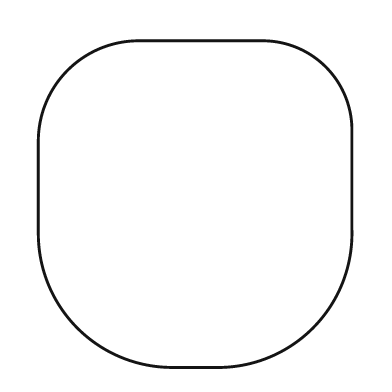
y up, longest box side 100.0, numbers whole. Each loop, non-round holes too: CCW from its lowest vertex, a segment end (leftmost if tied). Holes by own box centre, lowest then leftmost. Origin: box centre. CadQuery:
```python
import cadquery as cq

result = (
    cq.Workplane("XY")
    .moveTo(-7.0, -50.0)
    .lineTo(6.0, -50.0)
    .threePointArc((36.0, -38.0), (48.0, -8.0))
    .lineTo(48.0, 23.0)
    .threePointArc((40.0, 42.0), (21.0, 50.0))
    .lineTo(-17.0, 50.0)
    .threePointArc((-39.0, 41.0), (-48.0, 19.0))
    .lineTo(-48.0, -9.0)
    .threePointArc((-36.0, -38.0), (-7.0, -50.0))
    .close()
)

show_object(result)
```